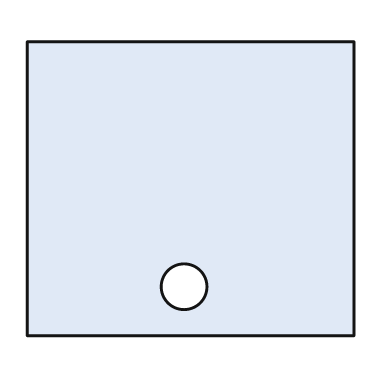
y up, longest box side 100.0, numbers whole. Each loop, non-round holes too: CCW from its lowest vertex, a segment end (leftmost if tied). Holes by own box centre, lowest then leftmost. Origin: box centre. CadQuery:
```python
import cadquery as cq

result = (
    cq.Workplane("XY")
    .moveTo(-50.0, -45.0)
    .lineTo(50.0, -45.0)
    .lineTo(50.0, 45.0)
    .lineTo(-50.0, 45.0)
    .close()
    .moveTo(-2.0, -30.0)
    .circle(7.0)
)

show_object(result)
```